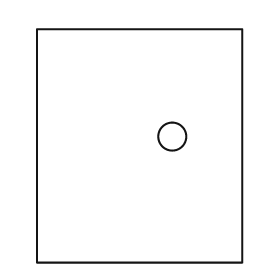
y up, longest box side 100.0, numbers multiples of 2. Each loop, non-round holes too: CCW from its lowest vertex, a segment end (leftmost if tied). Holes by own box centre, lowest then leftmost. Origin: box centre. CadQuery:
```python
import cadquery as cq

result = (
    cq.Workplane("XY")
    .moveTo(-44.0, -50.0)
    .lineTo(44.0, -50.0)
    .lineTo(44.0, 50.0)
    .lineTo(-44.0, 50.0)
    .close()
    .moveTo(14.0, 4.0)
    .circle(6.0)
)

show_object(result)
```